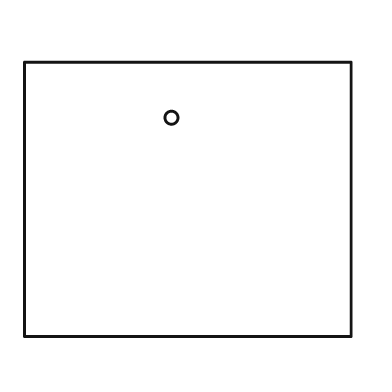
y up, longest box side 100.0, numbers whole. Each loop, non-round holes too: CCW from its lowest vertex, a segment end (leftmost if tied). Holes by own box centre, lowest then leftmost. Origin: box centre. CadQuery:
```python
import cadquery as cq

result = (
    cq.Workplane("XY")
    .moveTo(-50.0, -42.0)
    .lineTo(50.0, -42.0)
    .lineTo(50.0, 42.0)
    .lineTo(-50.0, 42.0)
    .close()
    .moveTo(-5.0, 25.0)
    .circle(2.0)
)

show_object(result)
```